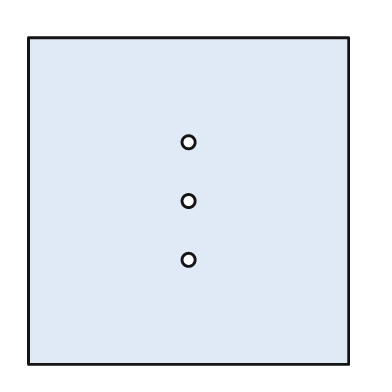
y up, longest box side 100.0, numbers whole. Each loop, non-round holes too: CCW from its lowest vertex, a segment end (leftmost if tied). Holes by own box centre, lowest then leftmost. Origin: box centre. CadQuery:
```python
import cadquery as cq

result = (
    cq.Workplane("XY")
    .moveTo(-49.0, -50.0)
    .lineTo(49.0, -50.0)
    .lineTo(49.0, 50.0)
    .lineTo(-49.0, 50.0)
    .close()
    .moveTo(0.0, -18.0)
    .circle(2.0)
    .moveTo(0.0, 0.0)
    .circle(2.0)
    .moveTo(0.0, 18.0)
    .circle(2.0)
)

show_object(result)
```